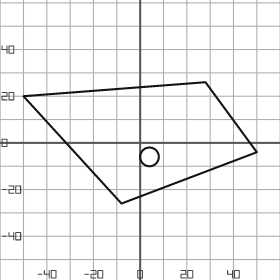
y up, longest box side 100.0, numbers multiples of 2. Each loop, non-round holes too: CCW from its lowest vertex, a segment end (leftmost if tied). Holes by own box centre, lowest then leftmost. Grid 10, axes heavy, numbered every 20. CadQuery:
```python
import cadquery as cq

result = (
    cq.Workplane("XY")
    .moveTo(-8.0, -26.0)
    .lineTo(50.0, -4.0)
    .lineTo(28.0, 26.0)
    .lineTo(-50.0, 20.0)
    .close()
    .moveTo(4.0, -6.0)
    .circle(4.0)
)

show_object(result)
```